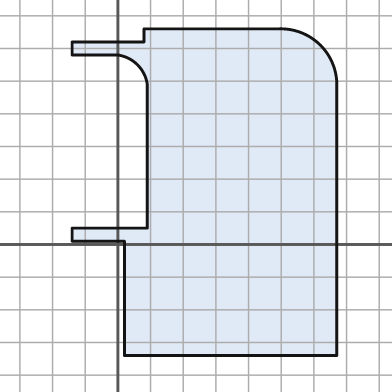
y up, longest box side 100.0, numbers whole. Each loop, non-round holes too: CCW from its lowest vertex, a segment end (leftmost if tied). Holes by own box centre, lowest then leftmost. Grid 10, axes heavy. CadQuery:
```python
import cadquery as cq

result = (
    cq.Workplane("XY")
    .moveTo(2.0, -34.0)
    .lineTo(67.0, -34.0)
    .lineTo(67.0, 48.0)
    .threePointArc((62.0, 61.0), (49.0, 66.0))
    .lineTo(8.0, 66.0)
    .lineTo(8.0, 62.0)
    .lineTo(-14.0, 62.0)
    .lineTo(-14.0, 58.0)
    .lineTo(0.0, 58.0)
    .threePointArc((6.0, 55.0), (9.0, 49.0))
    .lineTo(9.0, 5.0)
    .lineTo(-14.0, 5.0)
    .lineTo(-14.0, 1.0)
    .lineTo(2.0, 1.0)
    .close()
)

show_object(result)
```